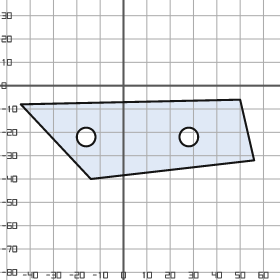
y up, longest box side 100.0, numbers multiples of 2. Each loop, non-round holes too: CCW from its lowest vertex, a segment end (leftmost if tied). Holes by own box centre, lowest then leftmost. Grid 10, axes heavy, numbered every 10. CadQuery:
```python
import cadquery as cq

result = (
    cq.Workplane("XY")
    .moveTo(-14.0, -40.0)
    .lineTo(56.0, -32.0)
    .lineTo(50.0, -6.0)
    .lineTo(-44.0, -8.0)
    .close()
    .moveTo(-16.0, -22.0)
    .circle(4.0)
    .moveTo(28.0, -22.0)
    .circle(4.0)
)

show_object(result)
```